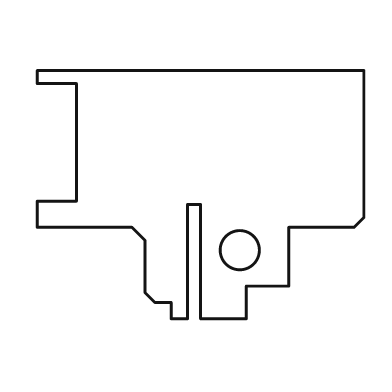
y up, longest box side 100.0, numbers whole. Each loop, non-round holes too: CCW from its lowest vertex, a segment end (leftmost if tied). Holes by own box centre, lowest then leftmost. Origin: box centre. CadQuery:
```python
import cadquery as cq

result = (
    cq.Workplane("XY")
    .moveTo(-9.0, -38.0)
    .lineTo(-4.0, -38.0)
    .lineTo(-4.0, -3.0)
    .lineTo(0.0, -3.0)
    .lineTo(0.0, -38.0)
    .lineTo(14.0, -38.0)
    .lineTo(14.0, -28.0)
    .lineTo(27.0, -28.0)
    .lineTo(27.0, -10.0)
    .lineTo(47.0, -10.0)
    .lineTo(50.0, -7.0)
    .lineTo(50.0, 38.0)
    .lineTo(-50.0, 38.0)
    .lineTo(-50.0, 34.0)
    .lineTo(-38.0, 34.0)
    .lineTo(-38.0, -2.0)
    .lineTo(-50.0, -2.0)
    .lineTo(-50.0, -10.0)
    .lineTo(-21.0, -10.0)
    .lineTo(-17.0, -14.0)
    .lineTo(-17.0, -30.0)
    .lineTo(-14.0, -33.0)
    .lineTo(-9.0, -33.0)
    .close()
    .moveTo(12.0, -17.0)
    .circle(6.0)
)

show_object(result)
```